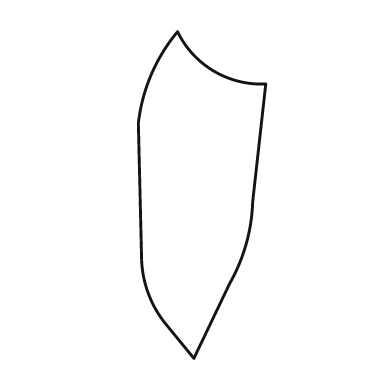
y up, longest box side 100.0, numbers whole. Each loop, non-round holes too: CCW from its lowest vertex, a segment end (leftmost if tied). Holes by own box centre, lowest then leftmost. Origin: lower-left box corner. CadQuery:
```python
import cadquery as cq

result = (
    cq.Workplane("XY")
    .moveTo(17.0, 0.0)
    .lineTo(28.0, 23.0)
    .threePointArc((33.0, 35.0), (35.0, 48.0))
    .lineTo(39.0, 84.0)
    .threePointArc((23.0, 88.0), (12.0, 100.0))
    .threePointArc((4.0, 87.0), (0.0, 72.0))
    .lineTo(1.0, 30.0)
    .threePointArc((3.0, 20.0), (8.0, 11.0))
    .close()
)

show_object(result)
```